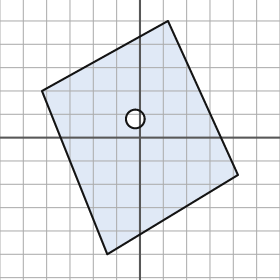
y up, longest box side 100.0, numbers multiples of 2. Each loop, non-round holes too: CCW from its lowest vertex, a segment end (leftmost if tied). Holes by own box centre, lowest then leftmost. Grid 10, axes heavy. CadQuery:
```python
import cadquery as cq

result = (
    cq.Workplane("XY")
    .moveTo(-14.0, -50.0)
    .lineTo(42.0, -16.0)
    .lineTo(12.0, 50.0)
    .lineTo(-42.0, 20.0)
    .close()
    .moveTo(-2.0, 8.0)
    .circle(4.0)
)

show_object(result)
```